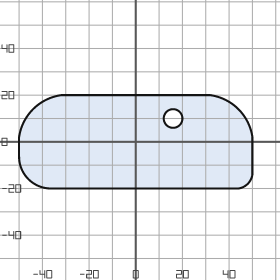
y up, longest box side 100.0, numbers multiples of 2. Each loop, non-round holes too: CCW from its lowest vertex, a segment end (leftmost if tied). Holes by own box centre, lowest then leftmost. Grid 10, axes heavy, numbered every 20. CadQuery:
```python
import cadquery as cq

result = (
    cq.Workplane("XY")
    .moveTo(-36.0, -20.0)
    .lineTo(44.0, -20.0)
    .threePointArc((48.0, -18.0), (50.0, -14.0))
    .lineTo(50.0, 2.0)
    .threePointArc((44.0, 14.0), (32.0, 20.0))
    .lineTo(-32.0, 20.0)
    .threePointArc((-44.0, 14.0), (-50.0, 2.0))
    .lineTo(-50.0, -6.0)
    .threePointArc((-46.0, -16.0), (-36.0, -20.0))
    .close()
    .moveTo(16.0, 10.0)
    .circle(4.0)
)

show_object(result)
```